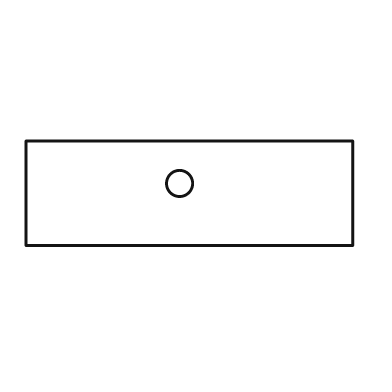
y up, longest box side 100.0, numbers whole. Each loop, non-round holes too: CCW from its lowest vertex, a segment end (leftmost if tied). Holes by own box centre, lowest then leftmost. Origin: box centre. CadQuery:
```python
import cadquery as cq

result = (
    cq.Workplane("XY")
    .moveTo(-50.0, -16.0)
    .lineTo(50.0, -16.0)
    .lineTo(50.0, 16.0)
    .lineTo(-50.0, 16.0)
    .close()
    .moveTo(-3.0, 3.0)
    .circle(4.0)
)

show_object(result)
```